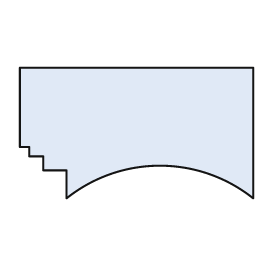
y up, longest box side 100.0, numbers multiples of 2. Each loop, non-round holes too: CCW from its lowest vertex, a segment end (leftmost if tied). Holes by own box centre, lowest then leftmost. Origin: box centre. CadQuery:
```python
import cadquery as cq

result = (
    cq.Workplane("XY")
    .moveTo(-30.0, -28.0)
    .threePointArc((10.0, -14.0), (50.0, -28.0))
    .lineTo(50.0, 28.0)
    .lineTo(-50.0, 28.0)
    .lineTo(-50.0, -6.0)
    .lineTo(-46.0, -6.0)
    .lineTo(-46.0, -10.0)
    .lineTo(-40.0, -10.0)
    .lineTo(-40.0, -16.0)
    .lineTo(-30.0, -16.0)
    .close()
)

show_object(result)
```